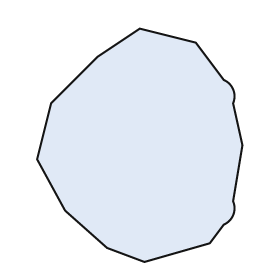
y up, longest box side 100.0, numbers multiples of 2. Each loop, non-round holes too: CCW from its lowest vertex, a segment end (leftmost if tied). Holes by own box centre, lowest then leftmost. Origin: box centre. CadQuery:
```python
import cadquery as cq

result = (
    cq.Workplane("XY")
    .moveTo(2.0, -50.0)
    .lineTo(30.0, -42.0)
    .lineTo(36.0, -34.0)
    .threePointArc((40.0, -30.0), (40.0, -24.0))
    .lineTo(44.0, 0.0)
    .lineTo(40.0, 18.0)
    .threePointArc((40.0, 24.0), (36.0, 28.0))
    .lineTo(24.0, 44.0)
    .lineTo(0.0, 50.0)
    .lineTo(-18.0, 38.0)
    .lineTo(-38.0, 18.0)
    .lineTo(-44.0, -6.0)
    .lineTo(-32.0, -28.0)
    .lineTo(-14.0, -44.0)
    .close()
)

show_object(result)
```